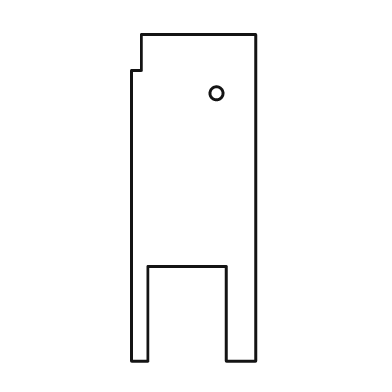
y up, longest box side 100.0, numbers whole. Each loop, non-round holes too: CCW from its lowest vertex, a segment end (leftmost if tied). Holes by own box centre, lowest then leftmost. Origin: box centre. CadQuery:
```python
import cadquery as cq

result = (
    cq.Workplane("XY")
    .moveTo(-19.0, -50.0)
    .lineTo(-14.0, -50.0)
    .lineTo(-14.0, -21.0)
    .lineTo(10.0, -21.0)
    .lineTo(10.0, -50.0)
    .lineTo(19.0, -50.0)
    .lineTo(19.0, 50.0)
    .lineTo(-16.0, 50.0)
    .lineTo(-16.0, 39.0)
    .lineTo(-19.0, 39.0)
    .close()
    .moveTo(7.0, 32.0)
    .circle(2.0)
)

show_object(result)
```